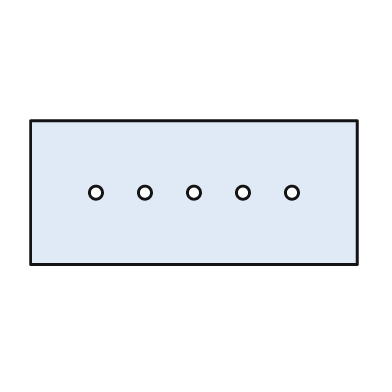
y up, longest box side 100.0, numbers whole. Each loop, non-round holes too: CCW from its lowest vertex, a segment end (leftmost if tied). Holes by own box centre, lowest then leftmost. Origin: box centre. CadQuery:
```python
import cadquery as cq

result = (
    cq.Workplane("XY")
    .moveTo(-50.0, -22.0)
    .lineTo(50.0, -22.0)
    .lineTo(50.0, 22.0)
    .lineTo(-50.0, 22.0)
    .close()
    .moveTo(-30.0, 0.0)
    .circle(2.0)
    .moveTo(-15.0, 0.0)
    .circle(2.0)
    .moveTo(0.0, 0.0)
    .circle(2.0)
    .moveTo(15.0, 0.0)
    .circle(2.0)
    .moveTo(30.0, 0.0)
    .circle(2.0)
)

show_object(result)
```